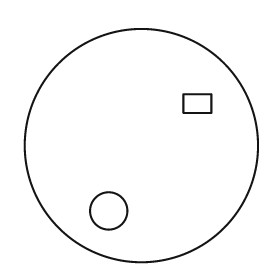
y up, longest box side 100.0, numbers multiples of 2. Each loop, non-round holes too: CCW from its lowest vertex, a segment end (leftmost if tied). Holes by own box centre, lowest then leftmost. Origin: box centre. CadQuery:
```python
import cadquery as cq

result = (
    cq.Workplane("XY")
    .moveTo(0.0, 0.0)
    .circle(50.0)
    .moveTo(-14.0, -28.0)
    .circle(8.0)
    .moveTo(18.0, 14.0)
    .lineTo(30.0, 14.0)
    .lineTo(30.0, 22.0)
    .lineTo(18.0, 22.0)
    .close()
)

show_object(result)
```